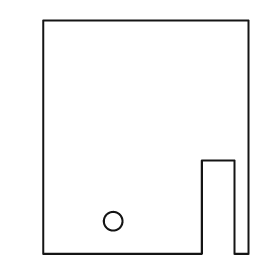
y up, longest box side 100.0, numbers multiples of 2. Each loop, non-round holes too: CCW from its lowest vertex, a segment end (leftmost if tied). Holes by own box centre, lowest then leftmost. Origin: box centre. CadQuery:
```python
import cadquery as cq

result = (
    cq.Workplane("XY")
    .moveTo(-44.0, -50.0)
    .lineTo(24.0, -50.0)
    .lineTo(24.0, -10.0)
    .lineTo(38.0, -10.0)
    .lineTo(38.0, -50.0)
    .lineTo(44.0, -50.0)
    .lineTo(44.0, 50.0)
    .lineTo(-44.0, 50.0)
    .close()
    .moveTo(-14.0, -36.0)
    .circle(4.0)
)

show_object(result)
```